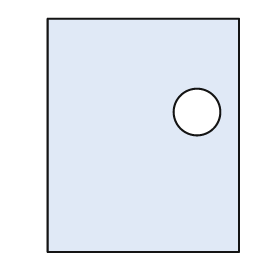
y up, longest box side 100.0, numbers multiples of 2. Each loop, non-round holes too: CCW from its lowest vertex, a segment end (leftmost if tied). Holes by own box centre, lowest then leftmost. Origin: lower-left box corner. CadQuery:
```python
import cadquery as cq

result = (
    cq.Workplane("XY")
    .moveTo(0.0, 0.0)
    .lineTo(82.0, 0.0)
    .lineTo(82.0, 100.0)
    .lineTo(0.0, 100.0)
    .close()
    .moveTo(64.0, 60.0)
    .circle(10.0)
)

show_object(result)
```